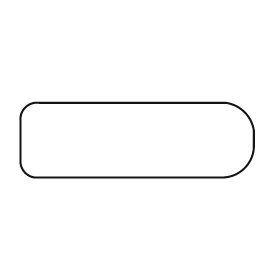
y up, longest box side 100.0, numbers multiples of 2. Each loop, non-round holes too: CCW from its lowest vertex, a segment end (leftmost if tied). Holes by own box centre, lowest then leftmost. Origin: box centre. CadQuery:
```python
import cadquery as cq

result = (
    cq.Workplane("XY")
    .moveTo(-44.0, -16.0)
    .lineTo(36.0, -16.0)
    .threePointArc((46.0, -12.0), (50.0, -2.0))
    .lineTo(50.0, 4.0)
    .threePointArc((46.0, 12.0), (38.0, 16.0))
    .lineTo(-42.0, 16.0)
    .threePointArc((-48.0, 14.0), (-50.0, 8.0))
    .lineTo(-50.0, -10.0)
    .threePointArc((-48.0, -14.0), (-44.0, -16.0))
    .close()
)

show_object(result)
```